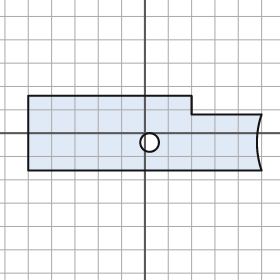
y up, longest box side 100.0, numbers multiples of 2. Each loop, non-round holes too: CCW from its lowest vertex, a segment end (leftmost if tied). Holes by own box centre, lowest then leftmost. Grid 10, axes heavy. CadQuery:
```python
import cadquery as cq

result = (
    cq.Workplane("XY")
    .moveTo(-50.0, -16.0)
    .lineTo(50.0, -16.0)
    .threePointArc((48.0, -4.0), (50.0, 8.0))
    .lineTo(20.0, 8.0)
    .lineTo(20.0, 16.0)
    .lineTo(-50.0, 16.0)
    .close()
    .moveTo(2.0, -4.0)
    .circle(4.0)
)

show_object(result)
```